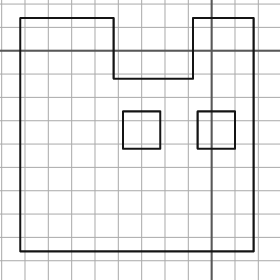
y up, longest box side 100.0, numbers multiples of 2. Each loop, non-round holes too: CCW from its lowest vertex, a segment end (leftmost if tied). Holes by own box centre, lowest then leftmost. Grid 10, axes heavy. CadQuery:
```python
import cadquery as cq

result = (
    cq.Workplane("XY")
    .moveTo(-82.0, -86.0)
    .lineTo(18.0, -86.0)
    .lineTo(18.0, 14.0)
    .lineTo(-8.0, 14.0)
    .lineTo(-8.0, -12.0)
    .lineTo(-42.0, -12.0)
    .lineTo(-42.0, 14.0)
    .lineTo(-82.0, 14.0)
    .close()
    .moveTo(-38.0, -42.0)
    .lineTo(-22.0, -42.0)
    .lineTo(-22.0, -26.0)
    .lineTo(-38.0, -26.0)
    .close()
    .moveTo(-6.0, -42.0)
    .lineTo(10.0, -42.0)
    .lineTo(10.0, -26.0)
    .lineTo(-6.0, -26.0)
    .close()
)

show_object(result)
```